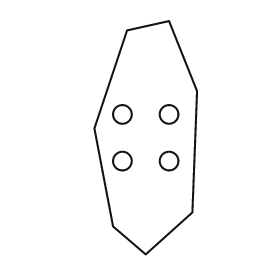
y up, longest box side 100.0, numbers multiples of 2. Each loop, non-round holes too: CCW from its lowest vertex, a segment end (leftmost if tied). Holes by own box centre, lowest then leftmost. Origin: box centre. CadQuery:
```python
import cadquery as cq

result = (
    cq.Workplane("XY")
    .moveTo(0.0, -50.0)
    .lineTo(20.0, -32.0)
    .lineTo(22.0, 20.0)
    .lineTo(10.0, 50.0)
    .lineTo(-8.0, 46.0)
    .lineTo(-22.0, 4.0)
    .lineTo(-14.0, -38.0)
    .close()
    .moveTo(-10.0, -10.0)
    .circle(4.0)
    .moveTo(10.0, -10.0)
    .circle(4.0)
    .moveTo(-10.0, 10.0)
    .circle(4.0)
    .moveTo(10.0, 10.0)
    .circle(4.0)
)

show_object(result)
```